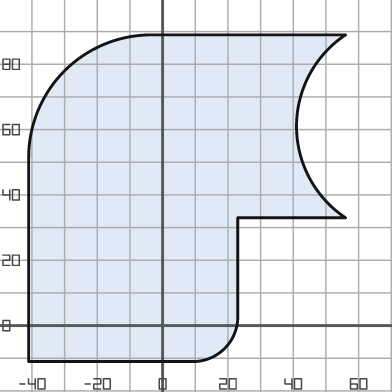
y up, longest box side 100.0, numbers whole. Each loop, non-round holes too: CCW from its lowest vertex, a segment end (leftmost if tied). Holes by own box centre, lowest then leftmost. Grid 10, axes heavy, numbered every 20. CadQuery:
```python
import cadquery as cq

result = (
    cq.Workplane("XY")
    .moveTo(-41.0, -11.0)
    .lineTo(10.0, -11.0)
    .threePointArc((19.0, -7.0), (23.0, 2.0))
    .lineTo(23.0, 33.0)
    .lineTo(56.0, 33.0)
    .threePointArc((41.0, 61.0), (56.0, 89.0))
    .lineTo(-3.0, 89.0)
    .threePointArc((-30.0, 78.0), (-41.0, 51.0))
    .close()
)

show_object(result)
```